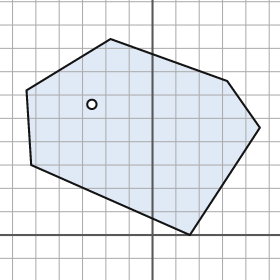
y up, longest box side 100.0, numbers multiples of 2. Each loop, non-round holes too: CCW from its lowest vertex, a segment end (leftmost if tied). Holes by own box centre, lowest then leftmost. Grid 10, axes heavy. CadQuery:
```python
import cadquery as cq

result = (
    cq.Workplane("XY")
    .moveTo(16.0, 0.0)
    .lineTo(46.0, 46.0)
    .lineTo(32.0, 66.0)
    .lineTo(-18.0, 84.0)
    .lineTo(-54.0, 62.0)
    .lineTo(-52.0, 30.0)
    .close()
    .moveTo(-26.0, 56.0)
    .circle(2.0)
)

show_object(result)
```